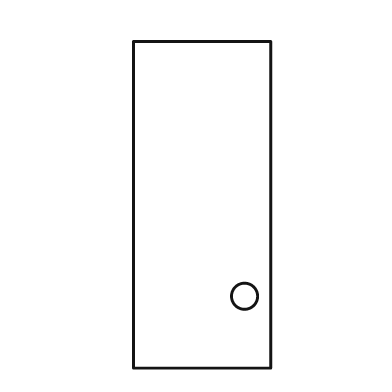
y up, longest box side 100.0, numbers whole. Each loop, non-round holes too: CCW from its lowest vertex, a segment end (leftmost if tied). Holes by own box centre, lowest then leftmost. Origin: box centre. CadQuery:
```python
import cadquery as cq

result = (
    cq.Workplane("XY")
    .moveTo(-21.0, -50.0)
    .lineTo(21.0, -50.0)
    .lineTo(21.0, 50.0)
    .lineTo(-21.0, 50.0)
    .close()
    .moveTo(13.0, -28.0)
    .circle(4.0)
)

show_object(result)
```